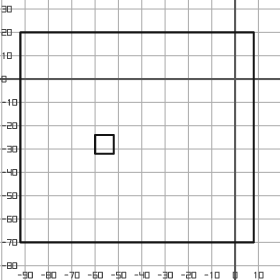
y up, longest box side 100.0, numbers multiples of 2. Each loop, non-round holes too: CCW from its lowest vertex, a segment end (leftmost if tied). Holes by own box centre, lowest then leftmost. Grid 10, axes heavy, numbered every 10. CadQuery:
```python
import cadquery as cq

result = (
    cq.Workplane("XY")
    .moveTo(-92.0, -70.0)
    .lineTo(8.0, -70.0)
    .lineTo(8.0, 20.0)
    .lineTo(-92.0, 20.0)
    .close()
    .moveTo(-60.0, -32.0)
    .lineTo(-52.0, -32.0)
    .lineTo(-52.0, -24.0)
    .lineTo(-60.0, -24.0)
    .close()
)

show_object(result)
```